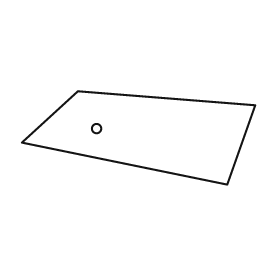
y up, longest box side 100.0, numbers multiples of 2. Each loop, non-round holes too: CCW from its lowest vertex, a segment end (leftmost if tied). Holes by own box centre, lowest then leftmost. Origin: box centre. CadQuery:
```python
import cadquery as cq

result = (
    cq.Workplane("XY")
    .moveTo(38.0, -20.0)
    .lineTo(50.0, 14.0)
    .lineTo(-26.0, 20.0)
    .lineTo(-50.0, -2.0)
    .close()
    .moveTo(-18.0, 4.0)
    .circle(2.0)
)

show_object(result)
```